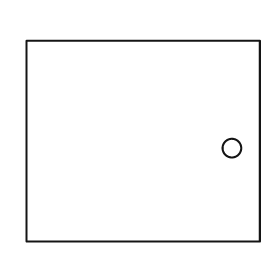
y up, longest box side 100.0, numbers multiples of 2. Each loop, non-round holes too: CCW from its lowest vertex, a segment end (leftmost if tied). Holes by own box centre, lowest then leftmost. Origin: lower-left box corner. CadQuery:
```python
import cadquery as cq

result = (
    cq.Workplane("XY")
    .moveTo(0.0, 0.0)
    .lineTo(100.0, 0.0)
    .lineTo(100.0, 86.0)
    .lineTo(0.0, 86.0)
    .close()
    .moveTo(88.0, 40.0)
    .circle(4.0)
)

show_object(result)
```